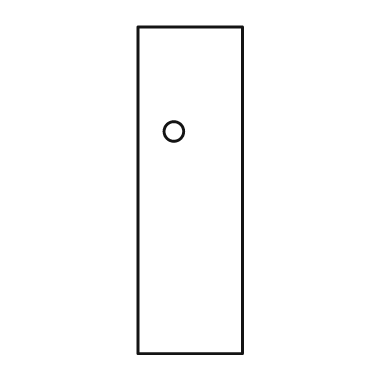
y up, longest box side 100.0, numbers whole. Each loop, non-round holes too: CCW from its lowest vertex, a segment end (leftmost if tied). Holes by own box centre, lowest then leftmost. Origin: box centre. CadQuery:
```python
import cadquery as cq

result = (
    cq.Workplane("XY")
    .moveTo(-16.0, -50.0)
    .lineTo(16.0, -50.0)
    .lineTo(16.0, 50.0)
    .lineTo(-16.0, 50.0)
    .close()
    .moveTo(-5.0, 18.0)
    .circle(3.0)
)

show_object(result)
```